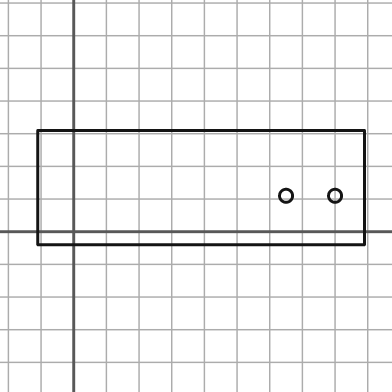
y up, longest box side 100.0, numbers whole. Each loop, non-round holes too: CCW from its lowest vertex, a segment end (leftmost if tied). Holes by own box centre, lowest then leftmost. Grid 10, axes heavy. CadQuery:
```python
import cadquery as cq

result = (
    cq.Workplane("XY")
    .moveTo(-11.0, -4.0)
    .lineTo(89.0, -4.0)
    .lineTo(89.0, 31.0)
    .lineTo(-11.0, 31.0)
    .close()
    .moveTo(65.0, 11.0)
    .circle(2.0)
    .moveTo(80.0, 11.0)
    .circle(2.0)
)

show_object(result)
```